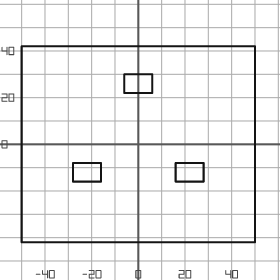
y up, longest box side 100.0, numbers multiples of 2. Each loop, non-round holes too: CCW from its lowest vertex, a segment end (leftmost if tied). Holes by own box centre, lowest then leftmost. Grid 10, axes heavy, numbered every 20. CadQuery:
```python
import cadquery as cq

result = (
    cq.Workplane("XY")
    .moveTo(-50.0, -42.0)
    .lineTo(50.0, -42.0)
    .lineTo(50.0, 42.0)
    .lineTo(-50.0, 42.0)
    .close()
    .moveTo(-28.0, -16.0)
    .lineTo(-16.0, -16.0)
    .lineTo(-16.0, -8.0)
    .lineTo(-28.0, -8.0)
    .close()
    .moveTo(16.0, -16.0)
    .lineTo(28.0, -16.0)
    .lineTo(28.0, -8.0)
    .lineTo(16.0, -8.0)
    .close()
    .moveTo(-6.0, 22.0)
    .lineTo(6.0, 22.0)
    .lineTo(6.0, 30.0)
    .lineTo(-6.0, 30.0)
    .close()
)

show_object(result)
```